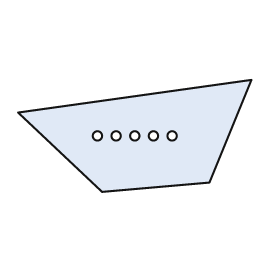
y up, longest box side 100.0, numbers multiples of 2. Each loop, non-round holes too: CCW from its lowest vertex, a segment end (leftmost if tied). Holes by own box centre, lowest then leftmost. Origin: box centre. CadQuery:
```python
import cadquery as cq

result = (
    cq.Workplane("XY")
    .moveTo(-14.0, -24.0)
    .lineTo(32.0, -20.0)
    .lineTo(50.0, 24.0)
    .lineTo(-50.0, 10.0)
    .close()
    .moveTo(-16.0, 0.0)
    .circle(2.0)
    .moveTo(-8.0, 0.0)
    .circle(2.0)
    .moveTo(0.0, 0.0)
    .circle(2.0)
    .moveTo(8.0, 0.0)
    .circle(2.0)
    .moveTo(16.0, 0.0)
    .circle(2.0)
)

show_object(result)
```